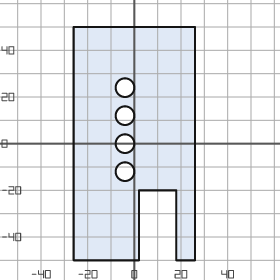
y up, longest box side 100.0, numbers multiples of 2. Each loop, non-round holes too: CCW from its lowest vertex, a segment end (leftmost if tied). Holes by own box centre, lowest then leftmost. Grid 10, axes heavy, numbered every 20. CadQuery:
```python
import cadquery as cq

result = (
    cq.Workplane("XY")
    .moveTo(-26.0, -50.0)
    .lineTo(2.0, -50.0)
    .lineTo(2.0, -20.0)
    .lineTo(18.0, -20.0)
    .lineTo(18.0, -50.0)
    .lineTo(26.0, -50.0)
    .lineTo(26.0, 50.0)
    .lineTo(-26.0, 50.0)
    .close()
    .moveTo(-4.0, -12.0)
    .circle(4.0)
    .moveTo(-4.0, 0.0)
    .circle(4.0)
    .moveTo(-4.0, 12.0)
    .circle(4.0)
    .moveTo(-4.0, 24.0)
    .circle(4.0)
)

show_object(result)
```